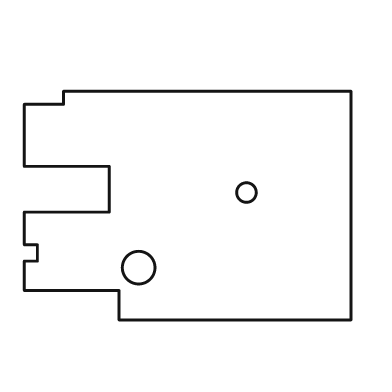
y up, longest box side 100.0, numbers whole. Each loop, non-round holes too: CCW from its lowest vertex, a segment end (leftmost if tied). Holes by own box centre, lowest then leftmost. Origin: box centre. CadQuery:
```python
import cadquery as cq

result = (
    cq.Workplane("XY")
    .moveTo(-21.0, -35.0)
    .lineTo(50.0, -35.0)
    .lineTo(50.0, 35.0)
    .lineTo(-38.0, 35.0)
    .lineTo(-38.0, 31.0)
    .lineTo(-50.0, 31.0)
    .lineTo(-50.0, 12.0)
    .lineTo(-24.0, 12.0)
    .lineTo(-24.0, -2.0)
    .lineTo(-50.0, -2.0)
    .lineTo(-50.0, -12.0)
    .lineTo(-46.0, -12.0)
    .lineTo(-46.0, -17.0)
    .lineTo(-50.0, -17.0)
    .lineTo(-50.0, -26.0)
    .lineTo(-21.0, -26.0)
    .close()
    .moveTo(-15.0, -19.0)
    .circle(5.0)
    .moveTo(18.0, 4.0)
    .circle(3.0)
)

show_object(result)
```